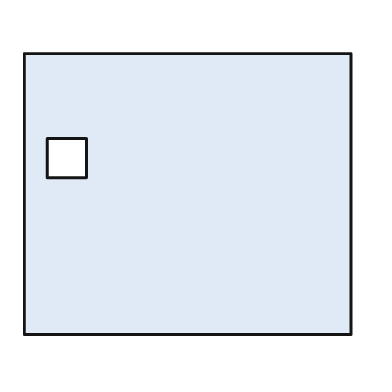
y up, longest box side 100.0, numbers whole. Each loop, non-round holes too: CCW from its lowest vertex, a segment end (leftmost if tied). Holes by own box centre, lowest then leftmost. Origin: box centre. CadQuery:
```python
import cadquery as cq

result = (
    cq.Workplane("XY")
    .moveTo(-50.0, -43.0)
    .lineTo(50.0, -43.0)
    .lineTo(50.0, 43.0)
    .lineTo(-50.0, 43.0)
    .close()
    .moveTo(-43.0, 5.0)
    .lineTo(-31.0, 5.0)
    .lineTo(-31.0, 17.0)
    .lineTo(-43.0, 17.0)
    .close()
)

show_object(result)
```